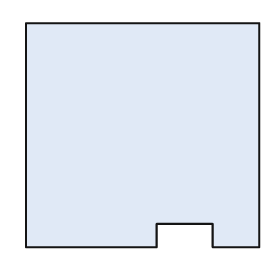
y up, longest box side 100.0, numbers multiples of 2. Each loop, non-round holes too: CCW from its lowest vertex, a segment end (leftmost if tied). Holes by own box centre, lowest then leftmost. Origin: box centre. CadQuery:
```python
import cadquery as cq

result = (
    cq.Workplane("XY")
    .moveTo(-50.0, -48.0)
    .lineTo(6.0, -48.0)
    .lineTo(6.0, -38.0)
    .lineTo(30.0, -38.0)
    .lineTo(30.0, -48.0)
    .lineTo(50.0, -48.0)
    .lineTo(50.0, 48.0)
    .lineTo(-50.0, 48.0)
    .close()
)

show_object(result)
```